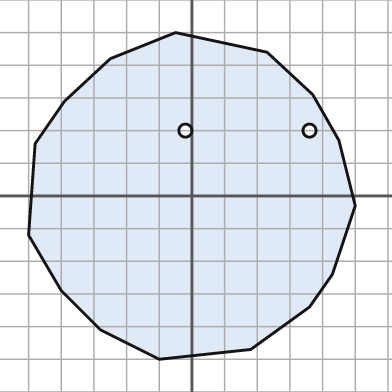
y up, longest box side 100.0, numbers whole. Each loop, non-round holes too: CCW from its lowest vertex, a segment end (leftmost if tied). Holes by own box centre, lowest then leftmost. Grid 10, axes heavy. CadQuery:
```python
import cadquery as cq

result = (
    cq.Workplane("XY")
    .moveTo(-10.0, -50.0)
    .lineTo(18.0, -47.0)
    .lineTo(36.0, -34.0)
    .lineTo(43.0, -24.0)
    .lineTo(50.0, -3.0)
    .lineTo(45.0, 17.0)
    .lineTo(37.0, 31.0)
    .lineTo(23.0, 44.0)
    .lineTo(-5.0, 50.0)
    .lineTo(-25.0, 42.0)
    .lineTo(-39.0, 29.0)
    .lineTo(-48.0, 16.0)
    .lineTo(-50.0, -12.0)
    .lineTo(-40.0, -29.0)
    .lineTo(-28.0, -41.0)
    .close()
    .moveTo(-2.0, 20.0)
    .circle(2.0)
    .moveTo(36.0, 20.0)
    .circle(2.0)
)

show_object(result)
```